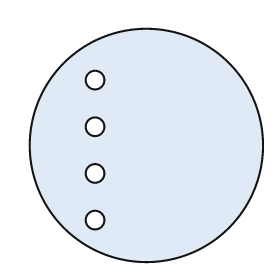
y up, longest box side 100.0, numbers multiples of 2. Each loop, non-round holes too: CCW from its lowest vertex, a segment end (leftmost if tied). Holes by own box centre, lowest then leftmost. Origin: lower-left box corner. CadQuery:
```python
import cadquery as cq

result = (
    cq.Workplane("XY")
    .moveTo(50.0, 50.0)
    .circle(50.0)
    .moveTo(28.0, 18.0)
    .circle(4.0)
    .moveTo(28.0, 38.0)
    .circle(4.0)
    .moveTo(28.0, 58.0)
    .circle(4.0)
    .moveTo(28.0, 78.0)
    .circle(4.0)
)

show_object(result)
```